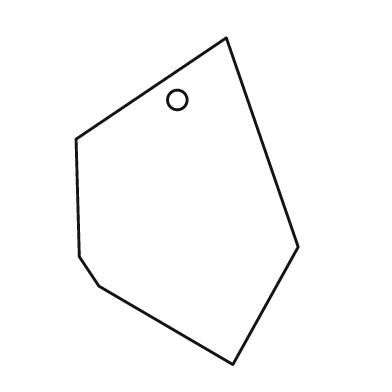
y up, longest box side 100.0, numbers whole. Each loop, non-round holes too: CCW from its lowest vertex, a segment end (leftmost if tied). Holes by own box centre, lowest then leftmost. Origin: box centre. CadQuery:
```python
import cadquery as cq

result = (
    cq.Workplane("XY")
    .moveTo(14.0, -50.0)
    .lineTo(34.0, -14.0)
    .lineTo(12.0, 50.0)
    .lineTo(-34.0, 19.0)
    .lineTo(-33.0, -17.0)
    .lineTo(-27.0, -26.0)
    .close()
    .moveTo(-3.0, 31.0)
    .circle(3.0)
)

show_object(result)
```